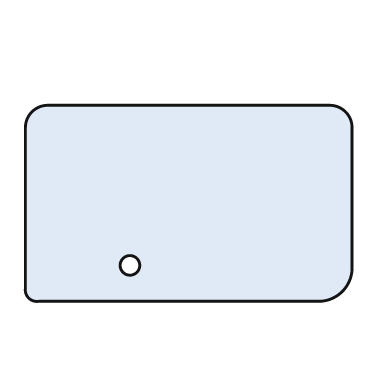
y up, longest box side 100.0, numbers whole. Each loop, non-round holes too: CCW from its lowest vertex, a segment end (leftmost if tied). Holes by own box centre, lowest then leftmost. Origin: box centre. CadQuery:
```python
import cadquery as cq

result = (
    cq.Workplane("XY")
    .moveTo(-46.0, -30.0)
    .lineTo(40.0, -30.0)
    .threePointArc((47.0, -27.0), (50.0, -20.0))
    .lineTo(50.0, 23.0)
    .threePointArc((48.0, 28.0), (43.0, 30.0))
    .lineTo(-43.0, 30.0)
    .threePointArc((-48.0, 28.0), (-50.0, 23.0))
    .lineTo(-50.0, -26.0)
    .threePointArc((-49.0, -29.0), (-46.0, -30.0))
    .close()
    .moveTo(-18.0, -19.0)
    .circle(3.0)
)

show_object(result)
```